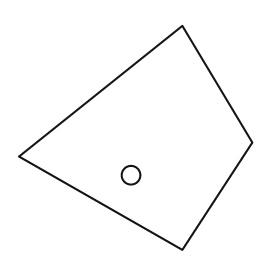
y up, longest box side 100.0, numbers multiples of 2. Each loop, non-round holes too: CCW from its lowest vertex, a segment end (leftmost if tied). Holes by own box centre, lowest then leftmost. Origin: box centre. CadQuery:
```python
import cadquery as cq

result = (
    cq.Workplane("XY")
    .moveTo(20.0, -48.0)
    .lineTo(50.0, -2.0)
    .lineTo(20.0, 48.0)
    .lineTo(-50.0, -8.0)
    .close()
    .moveTo(-2.0, -16.0)
    .circle(4.0)
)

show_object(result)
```